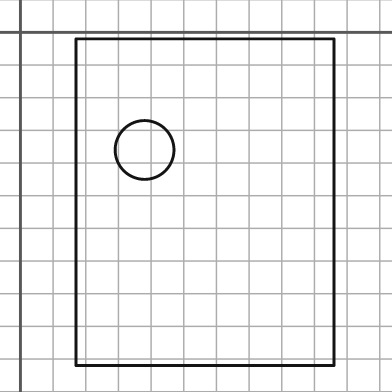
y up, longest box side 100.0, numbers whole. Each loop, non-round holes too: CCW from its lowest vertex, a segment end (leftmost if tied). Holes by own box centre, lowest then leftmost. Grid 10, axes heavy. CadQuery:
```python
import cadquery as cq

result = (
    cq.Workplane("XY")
    .moveTo(17.0, -102.0)
    .lineTo(96.0, -102.0)
    .lineTo(96.0, -2.0)
    .lineTo(17.0, -2.0)
    .close()
    .moveTo(38.0, -36.0)
    .circle(9.0)
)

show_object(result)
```